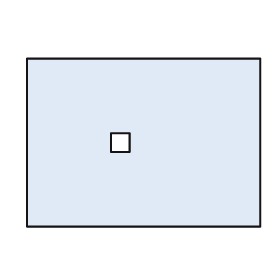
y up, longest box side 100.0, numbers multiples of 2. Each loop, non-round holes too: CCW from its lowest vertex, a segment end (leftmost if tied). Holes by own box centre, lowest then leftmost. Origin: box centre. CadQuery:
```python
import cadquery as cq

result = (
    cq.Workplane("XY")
    .moveTo(-50.0, -36.0)
    .lineTo(50.0, -36.0)
    .lineTo(50.0, 36.0)
    .lineTo(-50.0, 36.0)
    .close()
    .moveTo(-14.0, -4.0)
    .lineTo(-6.0, -4.0)
    .lineTo(-6.0, 4.0)
    .lineTo(-14.0, 4.0)
    .close()
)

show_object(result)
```